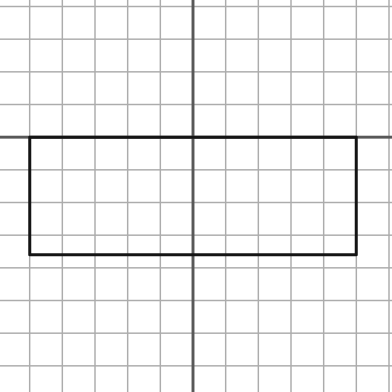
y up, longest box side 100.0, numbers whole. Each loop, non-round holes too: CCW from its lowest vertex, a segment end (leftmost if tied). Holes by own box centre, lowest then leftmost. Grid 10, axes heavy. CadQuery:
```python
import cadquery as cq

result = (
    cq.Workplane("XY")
    .moveTo(-50.0, -36.0)
    .lineTo(50.0, -36.0)
    .lineTo(50.0, 0.0)
    .lineTo(-50.0, 0.0)
    .close()
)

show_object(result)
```